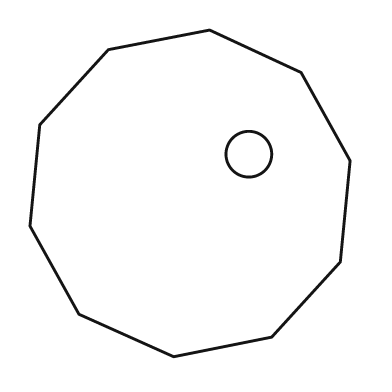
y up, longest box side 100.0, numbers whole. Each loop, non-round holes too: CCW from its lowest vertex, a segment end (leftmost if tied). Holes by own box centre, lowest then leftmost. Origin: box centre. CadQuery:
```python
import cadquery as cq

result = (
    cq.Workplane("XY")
    .moveTo(-5.0, -50.0)
    .lineTo(25.0, -44.0)
    .lineTo(46.0, -21.0)
    .lineTo(49.0, 10.0)
    .lineTo(34.0, 37.0)
    .lineTo(6.0, 50.0)
    .lineTo(-25.0, 44.0)
    .lineTo(-46.0, 21.0)
    .lineTo(-49.0, -10.0)
    .lineTo(-34.0, -37.0)
    .close()
    .moveTo(18.0, 12.0)
    .circle(7.0)
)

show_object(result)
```